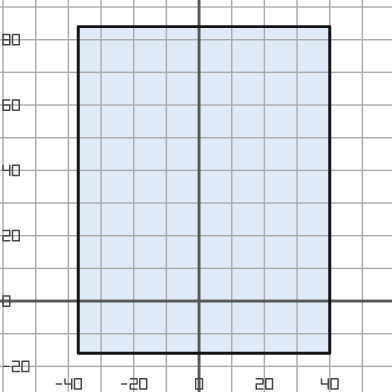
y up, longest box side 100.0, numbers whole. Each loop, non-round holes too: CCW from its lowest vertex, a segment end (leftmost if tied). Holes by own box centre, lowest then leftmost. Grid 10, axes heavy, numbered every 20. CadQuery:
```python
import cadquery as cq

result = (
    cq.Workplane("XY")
    .moveTo(-37.0, -16.0)
    .lineTo(40.0, -16.0)
    .lineTo(40.0, 84.0)
    .lineTo(-37.0, 84.0)
    .close()
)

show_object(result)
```